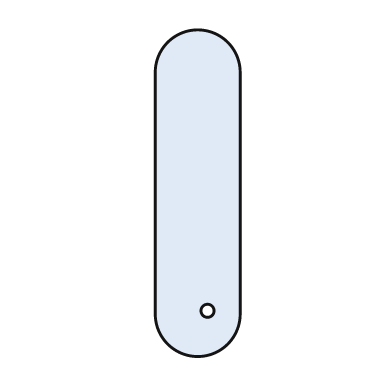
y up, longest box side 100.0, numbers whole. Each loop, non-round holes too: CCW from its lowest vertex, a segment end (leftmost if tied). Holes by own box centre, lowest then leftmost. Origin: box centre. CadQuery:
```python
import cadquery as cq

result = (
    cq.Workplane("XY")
    .moveTo(-13.0, -37.0)
    .threePointArc((0.0, -50.0), (13.0, -37.0))
    .lineTo(13.0, 37.0)
    .threePointArc((0.0, 50.0), (-13.0, 37.0))
    .close()
    .moveTo(3.0, -36.0)
    .circle(2.0)
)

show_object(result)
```